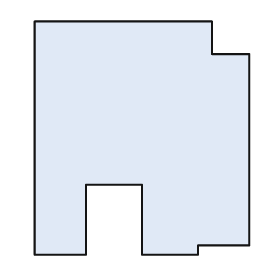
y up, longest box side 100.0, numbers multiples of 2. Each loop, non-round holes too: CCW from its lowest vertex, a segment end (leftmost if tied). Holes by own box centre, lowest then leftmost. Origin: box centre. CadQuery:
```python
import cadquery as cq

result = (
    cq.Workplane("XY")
    .moveTo(-46.0, -50.0)
    .lineTo(-24.0, -50.0)
    .lineTo(-24.0, -20.0)
    .lineTo(0.0, -20.0)
    .lineTo(0.0, -50.0)
    .lineTo(24.0, -50.0)
    .lineTo(24.0, -46.0)
    .lineTo(46.0, -46.0)
    .lineTo(46.0, 36.0)
    .lineTo(30.0, 36.0)
    .lineTo(30.0, 50.0)
    .lineTo(-46.0, 50.0)
    .close()
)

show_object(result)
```